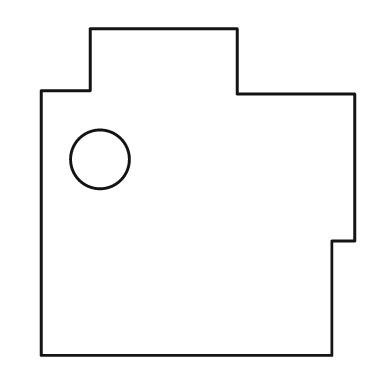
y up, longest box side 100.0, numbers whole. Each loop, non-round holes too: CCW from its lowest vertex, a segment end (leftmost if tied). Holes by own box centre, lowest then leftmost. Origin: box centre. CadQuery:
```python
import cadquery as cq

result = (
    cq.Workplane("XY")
    .moveTo(-48.0, -50.0)
    .lineTo(41.0, -50.0)
    .lineTo(41.0, -15.0)
    .lineTo(48.0, -15.0)
    .lineTo(48.0, 30.0)
    .lineTo(12.0, 30.0)
    .lineTo(12.0, 50.0)
    .lineTo(-33.0, 50.0)
    .lineTo(-33.0, 31.0)
    .lineTo(-48.0, 31.0)
    .close()
    .moveTo(-30.0, 10.0)
    .circle(9.0)
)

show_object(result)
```